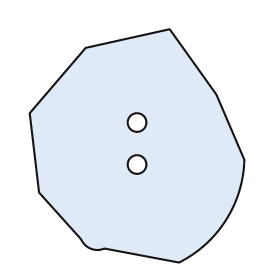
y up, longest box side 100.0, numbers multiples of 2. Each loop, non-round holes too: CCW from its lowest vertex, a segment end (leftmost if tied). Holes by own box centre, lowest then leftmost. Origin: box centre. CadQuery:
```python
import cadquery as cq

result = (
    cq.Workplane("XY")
    .moveTo(18.0, -50.0)
    .threePointArc((38.0, -32.0), (46.0, -6.0))
    .lineTo(34.0, 22.0)
    .lineTo(14.0, 50.0)
    .lineTo(-22.0, 42.0)
    .lineTo(-46.0, 14.0)
    .lineTo(-42.0, -20.0)
    .lineTo(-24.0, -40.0)
    .threePointArc((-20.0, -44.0), (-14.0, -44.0))
    .close()
    .moveTo(0.0, -8.0)
    .circle(4.0)
    .moveTo(0.0, 10.0)
    .circle(4.0)
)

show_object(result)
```